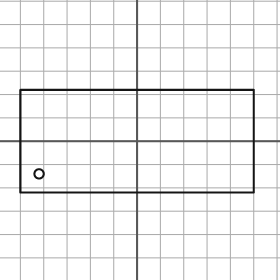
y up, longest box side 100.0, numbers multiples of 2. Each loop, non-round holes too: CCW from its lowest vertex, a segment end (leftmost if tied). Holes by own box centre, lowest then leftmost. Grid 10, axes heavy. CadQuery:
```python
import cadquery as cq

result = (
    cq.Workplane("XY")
    .moveTo(-50.0, -22.0)
    .lineTo(50.0, -22.0)
    .lineTo(50.0, 22.0)
    .lineTo(-50.0, 22.0)
    .close()
    .moveTo(-42.0, -14.0)
    .circle(2.0)
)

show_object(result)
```